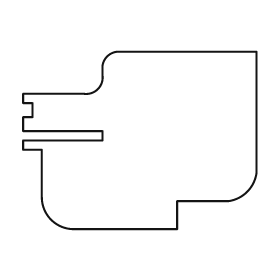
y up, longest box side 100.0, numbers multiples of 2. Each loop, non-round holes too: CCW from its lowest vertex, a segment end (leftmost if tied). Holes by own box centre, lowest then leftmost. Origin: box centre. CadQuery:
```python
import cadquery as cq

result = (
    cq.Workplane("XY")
    .moveTo(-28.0, -38.0)
    .lineTo(16.0, -38.0)
    .lineTo(16.0, -26.0)
    .lineTo(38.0, -26.0)
    .threePointArc((46.0, -22.0), (50.0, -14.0))
    .lineTo(50.0, 38.0)
    .lineTo(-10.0, 38.0)
    .threePointArc((-14.0, 36.0), (-16.0, 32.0))
    .lineTo(-16.0, 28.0)
    .threePointArc((-18.0, 22.0), (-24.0, 20.0))
    .lineTo(-50.0, 20.0)
    .lineTo(-50.0, 16.0)
    .lineTo(-46.0, 16.0)
    .lineTo(-46.0, 10.0)
    .lineTo(-50.0, 10.0)
    .lineTo(-50.0, 4.0)
    .lineTo(-16.0, 4.0)
    .lineTo(-16.0, 0.0)
    .lineTo(-50.0, 0.0)
    .lineTo(-50.0, -4.0)
    .lineTo(-42.0, -4.0)
    .lineTo(-42.0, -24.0)
    .threePointArc((-38.0, -34.0), (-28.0, -38.0))
    .close()
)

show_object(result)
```